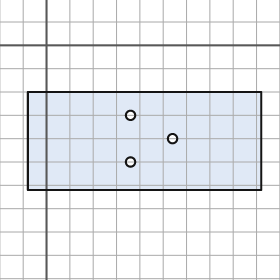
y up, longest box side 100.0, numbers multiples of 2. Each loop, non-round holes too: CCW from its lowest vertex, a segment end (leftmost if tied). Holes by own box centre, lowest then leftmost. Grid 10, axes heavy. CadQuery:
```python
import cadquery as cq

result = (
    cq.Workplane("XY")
    .moveTo(-8.0, -62.0)
    .lineTo(92.0, -62.0)
    .lineTo(92.0, -20.0)
    .lineTo(-8.0, -20.0)
    .close()
    .moveTo(36.0, -50.0)
    .circle(2.0)
    .moveTo(54.0, -40.0)
    .circle(2.0)
    .moveTo(36.0, -30.0)
    .circle(2.0)
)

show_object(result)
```